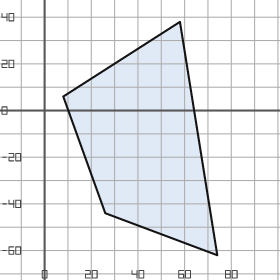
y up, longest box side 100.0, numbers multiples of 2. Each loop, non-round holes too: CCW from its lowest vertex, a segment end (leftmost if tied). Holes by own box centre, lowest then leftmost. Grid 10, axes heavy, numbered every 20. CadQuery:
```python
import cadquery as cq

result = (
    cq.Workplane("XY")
    .moveTo(74.0, -62.0)
    .lineTo(58.0, 38.0)
    .lineTo(8.0, 6.0)
    .lineTo(26.0, -44.0)
    .close()
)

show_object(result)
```